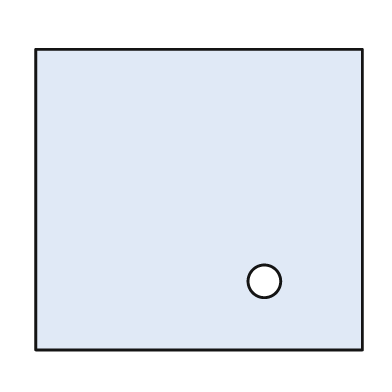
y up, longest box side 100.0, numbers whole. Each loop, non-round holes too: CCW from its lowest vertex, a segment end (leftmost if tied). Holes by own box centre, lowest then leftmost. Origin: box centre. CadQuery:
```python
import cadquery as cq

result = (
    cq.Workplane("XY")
    .moveTo(-50.0, -46.0)
    .lineTo(50.0, -46.0)
    .lineTo(50.0, 46.0)
    .lineTo(-50.0, 46.0)
    .close()
    .moveTo(20.0, -25.0)
    .circle(5.0)
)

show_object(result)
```